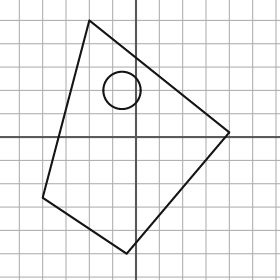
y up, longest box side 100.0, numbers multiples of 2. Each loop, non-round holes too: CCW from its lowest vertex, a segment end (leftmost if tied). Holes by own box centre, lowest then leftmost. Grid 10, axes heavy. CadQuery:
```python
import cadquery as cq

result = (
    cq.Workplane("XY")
    .moveTo(-4.0, -50.0)
    .lineTo(40.0, 2.0)
    .lineTo(-20.0, 50.0)
    .lineTo(-40.0, -26.0)
    .close()
    .moveTo(-6.0, 20.0)
    .circle(8.0)
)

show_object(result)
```